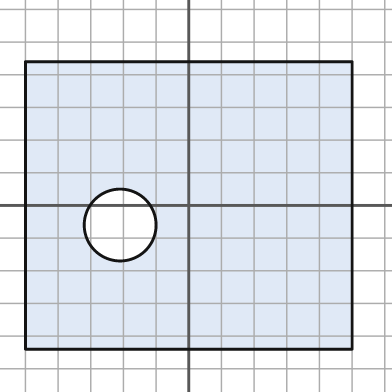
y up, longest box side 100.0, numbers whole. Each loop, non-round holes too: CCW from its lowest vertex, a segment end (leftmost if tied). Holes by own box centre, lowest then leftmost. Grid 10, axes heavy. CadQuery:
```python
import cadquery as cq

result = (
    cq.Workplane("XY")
    .moveTo(-50.0, -44.0)
    .lineTo(50.0, -44.0)
    .lineTo(50.0, 44.0)
    .lineTo(-50.0, 44.0)
    .close()
    .moveTo(-21.0, -6.0)
    .circle(11.0)
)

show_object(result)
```